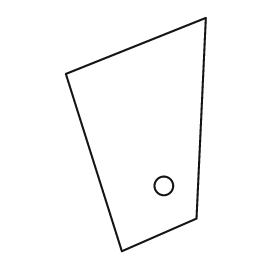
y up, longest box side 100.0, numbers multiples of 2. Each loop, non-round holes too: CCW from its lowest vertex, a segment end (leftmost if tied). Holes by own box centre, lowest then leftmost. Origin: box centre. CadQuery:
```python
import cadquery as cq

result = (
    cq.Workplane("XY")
    .moveTo(-6.0, -50.0)
    .lineTo(26.0, -36.0)
    .lineTo(30.0, 50.0)
    .lineTo(-30.0, 26.0)
    .close()
    .moveTo(12.0, -22.0)
    .circle(4.0)
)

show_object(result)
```